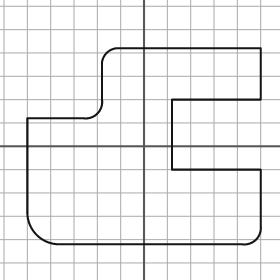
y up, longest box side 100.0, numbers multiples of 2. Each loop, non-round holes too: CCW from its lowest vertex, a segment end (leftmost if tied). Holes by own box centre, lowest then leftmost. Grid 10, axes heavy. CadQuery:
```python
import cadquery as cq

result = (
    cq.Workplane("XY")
    .moveTo(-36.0, -42.0)
    .lineTo(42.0, -42.0)
    .threePointArc((48.0, -40.0), (50.0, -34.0))
    .lineTo(50.0, -10.0)
    .lineTo(12.0, -10.0)
    .lineTo(12.0, 20.0)
    .lineTo(50.0, 20.0)
    .lineTo(50.0, 42.0)
    .lineTo(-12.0, 42.0)
    .threePointArc((-16.0, 40.0), (-18.0, 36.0))
    .lineTo(-18.0, 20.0)
    .threePointArc((-20.0, 14.0), (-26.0, 12.0))
    .lineTo(-50.0, 12.0)
    .lineTo(-50.0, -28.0)
    .threePointArc((-46.0, -38.0), (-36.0, -42.0))
    .close()
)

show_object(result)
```